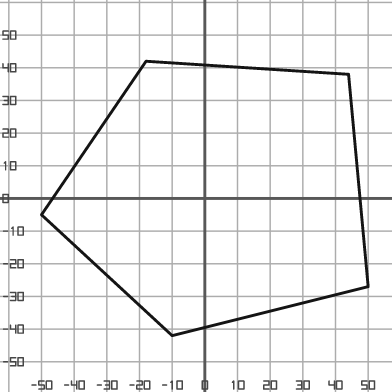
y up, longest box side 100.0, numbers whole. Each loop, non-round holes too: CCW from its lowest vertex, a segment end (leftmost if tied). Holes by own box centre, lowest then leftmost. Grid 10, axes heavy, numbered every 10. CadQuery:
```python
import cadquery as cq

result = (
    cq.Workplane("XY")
    .moveTo(-10.0, -42.0)
    .lineTo(50.0, -27.0)
    .lineTo(44.0, 38.0)
    .lineTo(-18.0, 42.0)
    .lineTo(-50.0, -5.0)
    .close()
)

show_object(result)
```